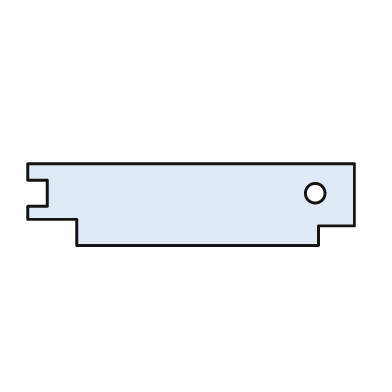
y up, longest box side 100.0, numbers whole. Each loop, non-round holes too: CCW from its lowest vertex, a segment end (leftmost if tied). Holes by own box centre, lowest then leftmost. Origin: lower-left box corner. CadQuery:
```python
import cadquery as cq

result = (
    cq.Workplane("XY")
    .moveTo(15.0, 0.0)
    .lineTo(89.0, 0.0)
    .lineTo(89.0, 6.0)
    .lineTo(100.0, 6.0)
    .lineTo(100.0, 25.0)
    .lineTo(0.0, 25.0)
    .lineTo(0.0, 20.0)
    .lineTo(6.0, 20.0)
    .lineTo(6.0, 12.0)
    .lineTo(0.0, 12.0)
    .lineTo(0.0, 8.0)
    .lineTo(15.0, 8.0)
    .close()
    .moveTo(88.0, 16.0)
    .circle(3.0)
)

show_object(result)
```